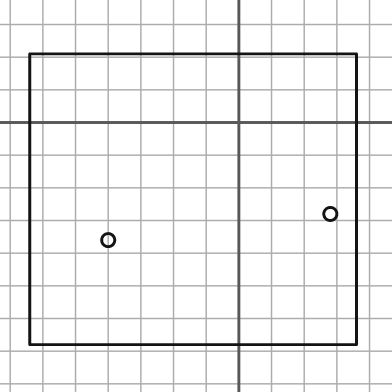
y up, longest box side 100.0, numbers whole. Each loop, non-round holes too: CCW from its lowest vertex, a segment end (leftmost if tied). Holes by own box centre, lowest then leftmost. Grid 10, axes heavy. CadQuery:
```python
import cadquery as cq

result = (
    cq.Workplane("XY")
    .moveTo(-64.0, -68.0)
    .lineTo(36.0, -68.0)
    .lineTo(36.0, 21.0)
    .lineTo(-64.0, 21.0)
    .close()
    .moveTo(-40.0, -36.0)
    .circle(2.0)
    .moveTo(28.0, -28.0)
    .circle(2.0)
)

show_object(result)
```